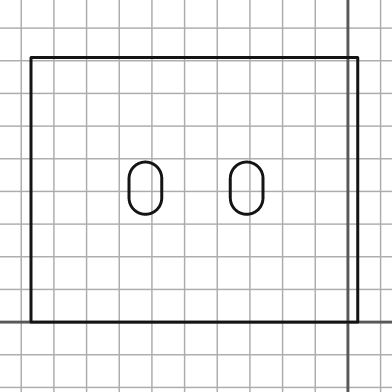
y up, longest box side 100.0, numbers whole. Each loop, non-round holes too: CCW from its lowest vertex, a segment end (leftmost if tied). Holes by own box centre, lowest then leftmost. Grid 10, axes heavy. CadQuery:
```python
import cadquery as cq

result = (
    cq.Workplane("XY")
    .moveTo(-97.0, 0.0)
    .lineTo(3.0, 0.0)
    .lineTo(3.0, 81.0)
    .lineTo(-97.0, 81.0)
    .close()
    .moveTo(-67.0, 38.0)
    .threePointArc((-62.0, 33.0), (-57.0, 38.0))
    .lineTo(-57.0, 44.0)
    .threePointArc((-62.0, 49.0), (-67.0, 44.0))
    .close()
    .moveTo(-36.0, 38.0)
    .threePointArc((-31.0, 33.0), (-26.0, 38.0))
    .lineTo(-26.0, 44.0)
    .threePointArc((-31.0, 49.0), (-36.0, 44.0))
    .close()
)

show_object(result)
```